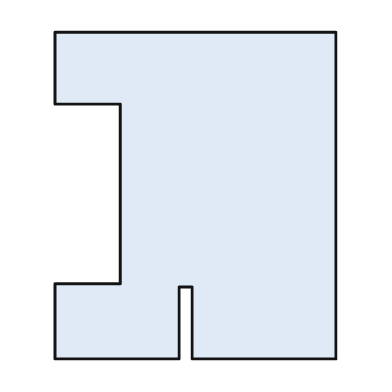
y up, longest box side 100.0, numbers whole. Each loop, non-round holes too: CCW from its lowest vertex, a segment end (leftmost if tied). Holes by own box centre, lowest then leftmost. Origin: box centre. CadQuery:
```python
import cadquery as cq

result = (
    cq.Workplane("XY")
    .moveTo(-43.0, -50.0)
    .lineTo(-5.0, -50.0)
    .lineTo(-5.0, -28.0)
    .lineTo(-1.0, -28.0)
    .lineTo(-1.0, -50.0)
    .lineTo(43.0, -50.0)
    .lineTo(43.0, 50.0)
    .lineTo(-43.0, 50.0)
    .lineTo(-43.0, 28.0)
    .lineTo(-23.0, 28.0)
    .lineTo(-23.0, -27.0)
    .lineTo(-43.0, -27.0)
    .close()
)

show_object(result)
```